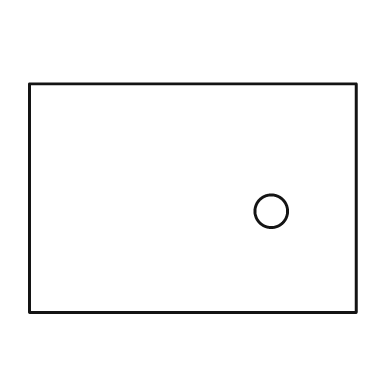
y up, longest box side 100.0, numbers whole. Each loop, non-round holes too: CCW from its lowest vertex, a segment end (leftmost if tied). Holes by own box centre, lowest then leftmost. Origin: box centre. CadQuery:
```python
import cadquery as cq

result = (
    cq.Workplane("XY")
    .moveTo(-50.0, -35.0)
    .lineTo(50.0, -35.0)
    .lineTo(50.0, 35.0)
    .lineTo(-50.0, 35.0)
    .close()
    .moveTo(24.0, -4.0)
    .circle(5.0)
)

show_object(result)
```